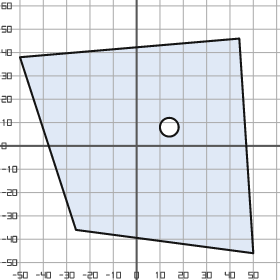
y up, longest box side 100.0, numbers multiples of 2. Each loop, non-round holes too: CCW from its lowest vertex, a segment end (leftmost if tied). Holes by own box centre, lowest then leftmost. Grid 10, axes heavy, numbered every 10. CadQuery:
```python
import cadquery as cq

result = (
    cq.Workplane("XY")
    .moveTo(50.0, -46.0)
    .lineTo(44.0, 46.0)
    .lineTo(-50.0, 38.0)
    .lineTo(-26.0, -36.0)
    .close()
    .moveTo(14.0, 8.0)
    .circle(4.0)
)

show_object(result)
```